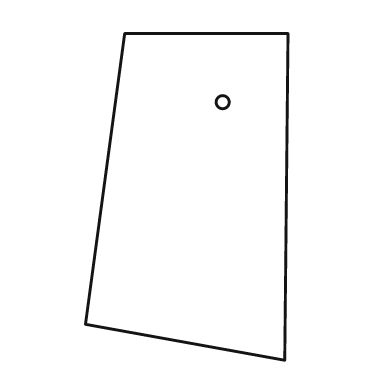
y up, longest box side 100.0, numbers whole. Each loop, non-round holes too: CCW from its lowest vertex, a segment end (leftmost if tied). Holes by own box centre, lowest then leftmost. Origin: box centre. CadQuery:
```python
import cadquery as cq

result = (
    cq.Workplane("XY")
    .moveTo(30.0, -50.0)
    .lineTo(31.0, 50.0)
    .lineTo(-19.0, 50.0)
    .lineTo(-31.0, -39.0)
    .close()
    .moveTo(11.0, 29.0)
    .circle(2.0)
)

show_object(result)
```